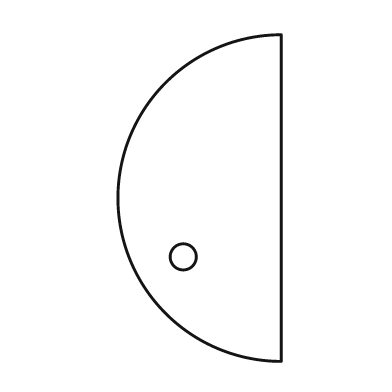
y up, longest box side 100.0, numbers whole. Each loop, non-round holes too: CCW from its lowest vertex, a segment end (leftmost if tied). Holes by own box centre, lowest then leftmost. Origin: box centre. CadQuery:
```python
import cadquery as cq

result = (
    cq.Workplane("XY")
    .moveTo(25.0, -50.0)
    .lineTo(25.0, 50.0)
    .threePointArc((-25.0, 0.0), (25.0, -50.0))
    .close()
    .moveTo(-5.0, -18.0)
    .circle(4.0)
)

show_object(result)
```